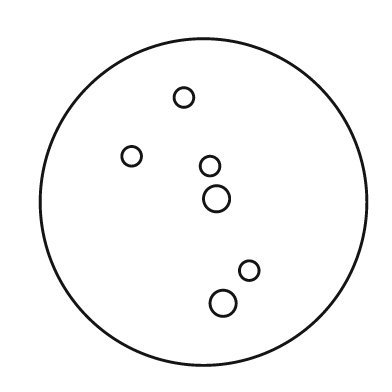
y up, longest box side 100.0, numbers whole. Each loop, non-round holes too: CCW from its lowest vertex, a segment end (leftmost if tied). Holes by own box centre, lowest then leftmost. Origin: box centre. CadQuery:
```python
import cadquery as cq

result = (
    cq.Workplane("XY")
    .moveTo(0.0, 0.0)
    .circle(50.0)
    .moveTo(6.0, -31.0)
    .circle(4.0)
    .moveTo(14.0, -21.0)
    .circle(3.0)
    .moveTo(4.0, 1.0)
    .circle(4.0)
    .moveTo(2.0, 11.0)
    .circle(3.0)
    .moveTo(-22.0, 14.0)
    .circle(3.0)
    .moveTo(-6.0, 32.0)
    .circle(3.0)
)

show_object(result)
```